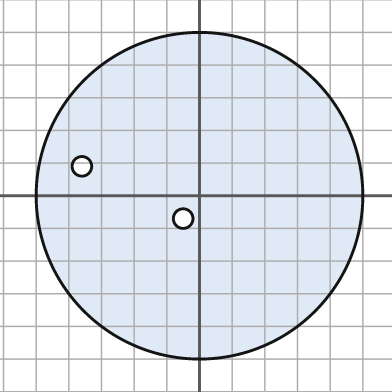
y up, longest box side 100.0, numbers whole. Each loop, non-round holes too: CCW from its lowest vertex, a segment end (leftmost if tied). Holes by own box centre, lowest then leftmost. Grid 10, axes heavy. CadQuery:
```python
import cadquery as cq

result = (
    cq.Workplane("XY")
    .moveTo(0.0, 0.0)
    .circle(50.0)
    .moveTo(-5.0, -7.0)
    .circle(3.0)
    .moveTo(-36.0, 9.0)
    .circle(3.0)
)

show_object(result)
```